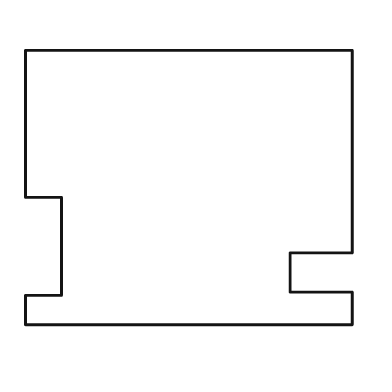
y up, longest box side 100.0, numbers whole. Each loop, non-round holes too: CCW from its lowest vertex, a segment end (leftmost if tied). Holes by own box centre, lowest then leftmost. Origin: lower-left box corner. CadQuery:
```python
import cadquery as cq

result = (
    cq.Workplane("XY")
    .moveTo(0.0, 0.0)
    .lineTo(100.0, 0.0)
    .lineTo(100.0, 10.0)
    .lineTo(81.0, 10.0)
    .lineTo(81.0, 22.0)
    .lineTo(100.0, 22.0)
    .lineTo(100.0, 84.0)
    .lineTo(0.0, 84.0)
    .lineTo(0.0, 39.0)
    .lineTo(11.0, 39.0)
    .lineTo(11.0, 9.0)
    .lineTo(0.0, 9.0)
    .close()
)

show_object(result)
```